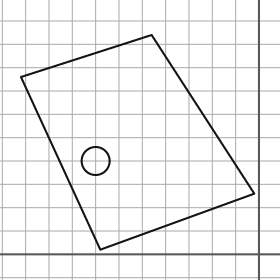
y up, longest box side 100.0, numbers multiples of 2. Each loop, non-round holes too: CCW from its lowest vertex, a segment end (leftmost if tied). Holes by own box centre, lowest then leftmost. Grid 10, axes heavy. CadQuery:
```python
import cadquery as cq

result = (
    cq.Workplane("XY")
    .moveTo(-68.0, 2.0)
    .lineTo(-2.0, 26.0)
    .lineTo(-46.0, 94.0)
    .lineTo(-102.0, 76.0)
    .close()
    .moveTo(-70.0, 40.0)
    .circle(6.0)
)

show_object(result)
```